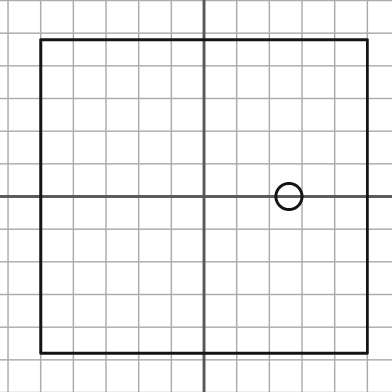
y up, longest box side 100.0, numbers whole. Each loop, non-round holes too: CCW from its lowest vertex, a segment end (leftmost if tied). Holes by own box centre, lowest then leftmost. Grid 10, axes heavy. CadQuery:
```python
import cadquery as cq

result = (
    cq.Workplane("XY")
    .moveTo(-50.0, -48.0)
    .lineTo(50.0, -48.0)
    .lineTo(50.0, 48.0)
    .lineTo(-50.0, 48.0)
    .close()
    .moveTo(26.0, 0.0)
    .circle(4.0)
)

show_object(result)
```